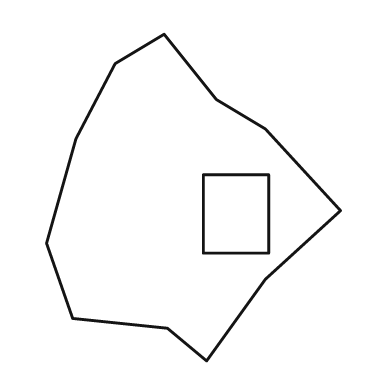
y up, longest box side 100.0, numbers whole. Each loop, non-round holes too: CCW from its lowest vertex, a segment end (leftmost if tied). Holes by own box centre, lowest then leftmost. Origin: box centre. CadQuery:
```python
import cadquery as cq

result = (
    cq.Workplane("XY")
    .moveTo(4.0, -50.0)
    .lineTo(22.0, -25.0)
    .lineTo(45.0, -4.0)
    .lineTo(22.0, 21.0)
    .lineTo(7.0, 30.0)
    .lineTo(-9.0, 50.0)
    .lineTo(-24.0, 41.0)
    .lineTo(-36.0, 18.0)
    .lineTo(-45.0, -14.0)
    .lineTo(-37.0, -37.0)
    .lineTo(-8.0, -40.0)
    .close()
    .moveTo(3.0, -17.0)
    .lineTo(23.0, -17.0)
    .lineTo(23.0, 7.0)
    .lineTo(3.0, 7.0)
    .close()
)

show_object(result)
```